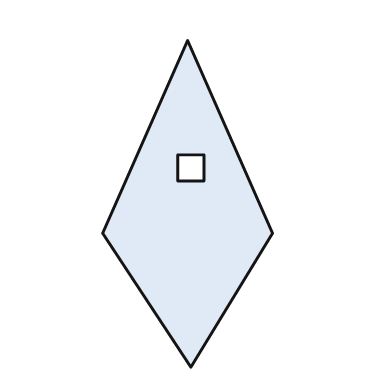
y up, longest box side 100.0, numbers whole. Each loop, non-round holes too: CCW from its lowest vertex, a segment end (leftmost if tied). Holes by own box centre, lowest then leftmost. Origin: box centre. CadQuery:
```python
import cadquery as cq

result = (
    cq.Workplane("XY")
    .moveTo(1.0, -50.0)
    .lineTo(26.0, -9.0)
    .lineTo(0.0, 50.0)
    .lineTo(-26.0, -9.0)
    .close()
    .moveTo(-3.0, 7.0)
    .lineTo(5.0, 7.0)
    .lineTo(5.0, 15.0)
    .lineTo(-3.0, 15.0)
    .close()
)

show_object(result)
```